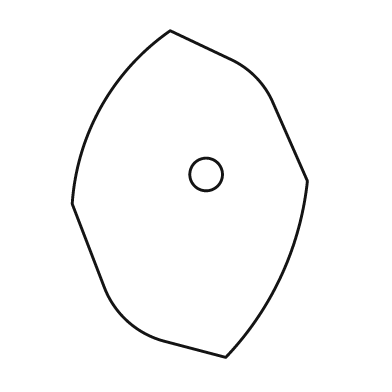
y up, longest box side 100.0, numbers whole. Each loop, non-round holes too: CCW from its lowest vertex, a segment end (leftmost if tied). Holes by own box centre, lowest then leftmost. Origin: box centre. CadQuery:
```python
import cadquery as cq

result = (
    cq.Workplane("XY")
    .moveTo(11.0, -50.0)
    .threePointArc((28.0, -25.0), (36.0, 4.0))
    .lineTo(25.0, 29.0)
    .threePointArc((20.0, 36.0), (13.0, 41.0))
    .lineTo(-6.0, 50.0)
    .threePointArc((-27.0, 27.0), (-36.0, -3.0))
    .lineTo(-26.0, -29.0)
    .threePointArc((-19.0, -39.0), (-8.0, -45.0))
    .close()
    .moveTo(5.0, 6.0)
    .circle(5.0)
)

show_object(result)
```